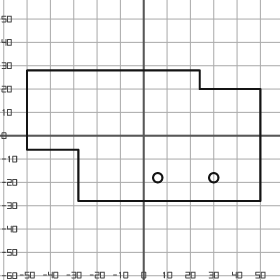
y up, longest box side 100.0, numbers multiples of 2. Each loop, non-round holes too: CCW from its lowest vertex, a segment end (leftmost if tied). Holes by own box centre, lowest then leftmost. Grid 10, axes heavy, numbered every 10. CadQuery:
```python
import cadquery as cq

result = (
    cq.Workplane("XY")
    .moveTo(-28.0, -28.0)
    .lineTo(50.0, -28.0)
    .lineTo(50.0, 20.0)
    .lineTo(24.0, 20.0)
    .lineTo(24.0, 28.0)
    .lineTo(-50.0, 28.0)
    .lineTo(-50.0, -6.0)
    .lineTo(-28.0, -6.0)
    .close()
    .moveTo(6.0, -18.0)
    .circle(2.0)
    .moveTo(30.0, -18.0)
    .circle(2.0)
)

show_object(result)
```